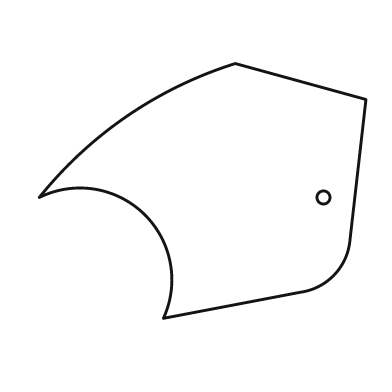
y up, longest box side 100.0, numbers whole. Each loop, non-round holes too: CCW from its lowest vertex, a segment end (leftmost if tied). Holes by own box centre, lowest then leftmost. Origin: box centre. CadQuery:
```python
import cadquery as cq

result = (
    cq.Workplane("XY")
    .moveTo(-12.0, -39.0)
    .lineTo(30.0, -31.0)
    .threePointArc((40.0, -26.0), (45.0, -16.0))
    .lineTo(50.0, 28.0)
    .lineTo(10.0, 39.0)
    .threePointArc((-23.0, 23.0), (-50.0, -2.0))
    .threePointArc((-18.0, -7.0), (-12.0, -39.0))
    .close()
    .moveTo(37.0, -2.0)
    .circle(2.0)
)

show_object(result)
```